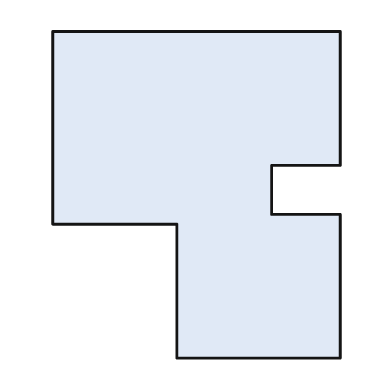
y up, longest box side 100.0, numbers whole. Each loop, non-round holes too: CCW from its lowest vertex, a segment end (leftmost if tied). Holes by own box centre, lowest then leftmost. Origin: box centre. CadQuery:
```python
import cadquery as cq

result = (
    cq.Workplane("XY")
    .moveTo(-6.0, -50.0)
    .lineTo(44.0, -50.0)
    .lineTo(44.0, -6.0)
    .lineTo(23.0, -6.0)
    .lineTo(23.0, 9.0)
    .lineTo(44.0, 9.0)
    .lineTo(44.0, 50.0)
    .lineTo(-44.0, 50.0)
    .lineTo(-44.0, -9.0)
    .lineTo(-6.0, -9.0)
    .close()
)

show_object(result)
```